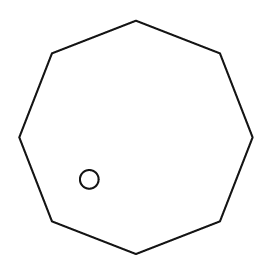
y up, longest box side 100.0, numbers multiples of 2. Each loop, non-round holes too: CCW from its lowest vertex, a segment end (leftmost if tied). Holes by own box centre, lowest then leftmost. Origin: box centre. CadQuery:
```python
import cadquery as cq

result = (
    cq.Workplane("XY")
    .moveTo(0.0, -50.0)
    .lineTo(36.0, -36.0)
    .lineTo(50.0, 0.0)
    .lineTo(36.0, 36.0)
    .lineTo(0.0, 50.0)
    .lineTo(-36.0, 36.0)
    .lineTo(-50.0, 0.0)
    .lineTo(-36.0, -36.0)
    .close()
    .moveTo(-20.0, -18.0)
    .circle(4.0)
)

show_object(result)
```